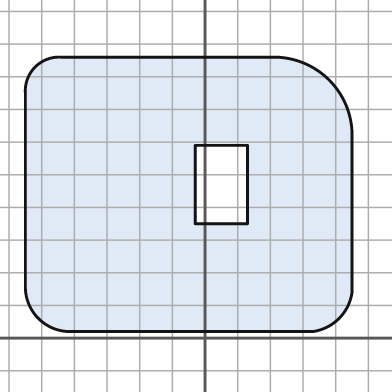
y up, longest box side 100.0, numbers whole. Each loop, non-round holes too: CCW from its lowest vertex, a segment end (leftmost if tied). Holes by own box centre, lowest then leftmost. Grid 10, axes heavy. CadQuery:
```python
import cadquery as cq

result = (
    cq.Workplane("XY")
    .moveTo(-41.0, 2.0)
    .lineTo(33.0, 2.0)
    .threePointArc((41.0, 6.0), (45.0, 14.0))
    .lineTo(45.0, 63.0)
    .threePointArc((38.0, 79.0), (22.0, 86.0))
    .lineTo(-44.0, 86.0)
    .threePointArc((-52.0, 83.0), (-55.0, 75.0))
    .lineTo(-55.0, 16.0)
    .threePointArc((-51.0, 6.0), (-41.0, 2.0))
    .close()
    .moveTo(-3.0, 35.0)
    .lineTo(13.0, 35.0)
    .lineTo(13.0, 59.0)
    .lineTo(-3.0, 59.0)
    .close()
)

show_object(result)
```